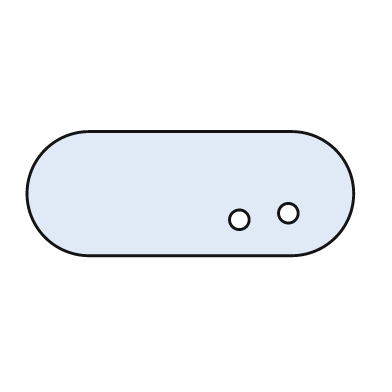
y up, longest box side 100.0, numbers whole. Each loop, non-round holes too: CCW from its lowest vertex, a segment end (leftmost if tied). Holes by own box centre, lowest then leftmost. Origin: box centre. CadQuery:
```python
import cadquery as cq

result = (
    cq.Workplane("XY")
    .moveTo(-31.0, -19.0)
    .lineTo(31.0, -19.0)
    .threePointArc((50.0, 0.0), (31.0, 19.0))
    .lineTo(-31.0, 19.0)
    .threePointArc((-50.0, 0.0), (-31.0, -19.0))
    .close()
    .moveTo(15.0, -8.0)
    .circle(3.0)
    .moveTo(30.0, -6.0)
    .circle(3.0)
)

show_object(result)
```